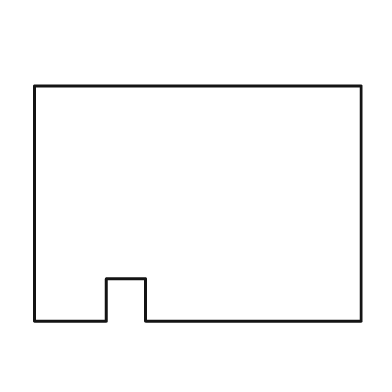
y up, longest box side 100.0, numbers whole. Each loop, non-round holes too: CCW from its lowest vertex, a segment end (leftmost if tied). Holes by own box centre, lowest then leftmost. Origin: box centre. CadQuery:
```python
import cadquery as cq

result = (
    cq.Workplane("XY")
    .moveTo(-50.0, -36.0)
    .lineTo(-28.0, -36.0)
    .lineTo(-28.0, -23.0)
    .lineTo(-16.0, -23.0)
    .lineTo(-16.0, -36.0)
    .lineTo(50.0, -36.0)
    .lineTo(50.0, 36.0)
    .lineTo(-50.0, 36.0)
    .close()
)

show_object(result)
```